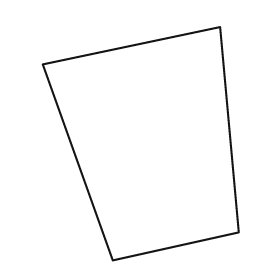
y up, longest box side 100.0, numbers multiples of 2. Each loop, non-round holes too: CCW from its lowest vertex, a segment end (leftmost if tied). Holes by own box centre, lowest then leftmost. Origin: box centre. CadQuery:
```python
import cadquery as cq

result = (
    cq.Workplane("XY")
    .moveTo(-12.0, -50.0)
    .lineTo(42.0, -38.0)
    .lineTo(34.0, 50.0)
    .lineTo(-42.0, 34.0)
    .close()
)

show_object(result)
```